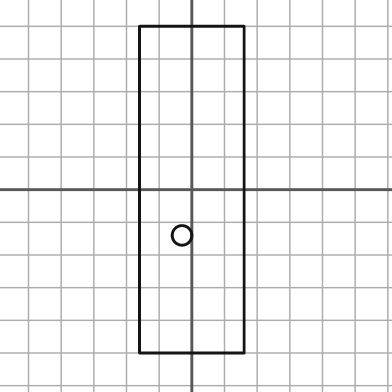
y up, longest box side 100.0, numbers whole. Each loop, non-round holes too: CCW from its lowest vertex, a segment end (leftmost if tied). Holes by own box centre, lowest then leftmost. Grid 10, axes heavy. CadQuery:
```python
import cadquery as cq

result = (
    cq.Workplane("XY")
    .moveTo(-16.0, -50.0)
    .lineTo(16.0, -50.0)
    .lineTo(16.0, 50.0)
    .lineTo(-16.0, 50.0)
    .close()
    .moveTo(-3.0, -14.0)
    .circle(3.0)
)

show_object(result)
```